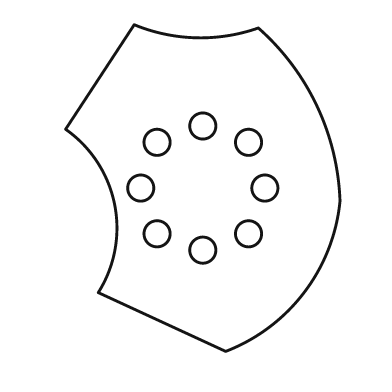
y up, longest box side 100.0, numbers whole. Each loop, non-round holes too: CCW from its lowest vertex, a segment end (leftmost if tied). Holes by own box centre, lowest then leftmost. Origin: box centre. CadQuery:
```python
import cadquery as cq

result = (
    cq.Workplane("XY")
    .moveTo(7.0, -50.0)
    .threePointArc((31.0, -32.0), (42.0, -4.0))
    .threePointArc((35.0, 25.0), (17.0, 49.0))
    .threePointArc((-2.0, 46.0), (-21.0, 50.0))
    .lineTo(-42.0, 18.0)
    .threePointArc((-27.0, -5.0), (-32.0, -32.0))
    .close()
    .moveTo(0.0, -19.0)
    .circle(4.0)
    .moveTo(-14.0, -14.0)
    .circle(4.0)
    .moveTo(14.0, -14.0)
    .circle(4.0)
    .moveTo(-19.0, 0.0)
    .circle(4.0)
    .moveTo(19.0, 0.0)
    .circle(4.0)
    .moveTo(-14.0, 14.0)
    .circle(4.0)
    .moveTo(14.0, 14.0)
    .circle(4.0)
    .moveTo(0.0, 19.0)
    .circle(4.0)
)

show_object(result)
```